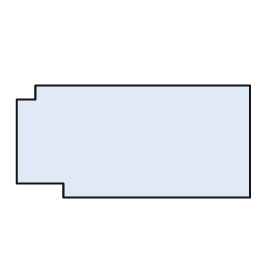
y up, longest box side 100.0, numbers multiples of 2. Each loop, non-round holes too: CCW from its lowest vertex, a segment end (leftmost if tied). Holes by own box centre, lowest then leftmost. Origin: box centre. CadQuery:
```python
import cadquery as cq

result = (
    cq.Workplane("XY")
    .moveTo(-30.0, -24.0)
    .lineTo(50.0, -24.0)
    .lineTo(50.0, 24.0)
    .lineTo(-42.0, 24.0)
    .lineTo(-42.0, 18.0)
    .lineTo(-50.0, 18.0)
    .lineTo(-50.0, -18.0)
    .lineTo(-30.0, -18.0)
    .close()
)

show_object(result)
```